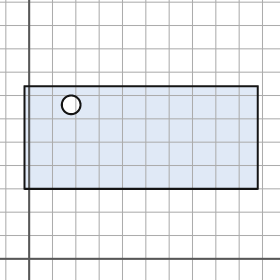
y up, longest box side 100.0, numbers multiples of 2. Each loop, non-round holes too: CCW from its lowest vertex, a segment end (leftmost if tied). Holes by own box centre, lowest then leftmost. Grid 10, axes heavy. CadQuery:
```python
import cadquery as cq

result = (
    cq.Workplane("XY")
    .moveTo(-2.0, 30.0)
    .lineTo(98.0, 30.0)
    .lineTo(98.0, 74.0)
    .lineTo(-2.0, 74.0)
    .close()
    .moveTo(18.0, 66.0)
    .circle(4.0)
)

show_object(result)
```